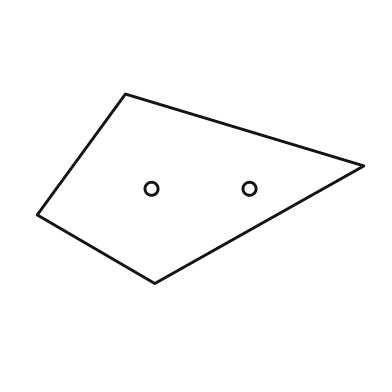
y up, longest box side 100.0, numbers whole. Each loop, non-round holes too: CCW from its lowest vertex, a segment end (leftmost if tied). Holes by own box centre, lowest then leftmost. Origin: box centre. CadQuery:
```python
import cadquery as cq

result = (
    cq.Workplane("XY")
    .moveTo(-14.0, -29.0)
    .lineTo(50.0, 7.0)
    .lineTo(-23.0, 29.0)
    .lineTo(-50.0, -8.0)
    .close()
    .moveTo(-15.0, 0.0)
    .circle(2.0)
    .moveTo(15.0, 0.0)
    .circle(2.0)
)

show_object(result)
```